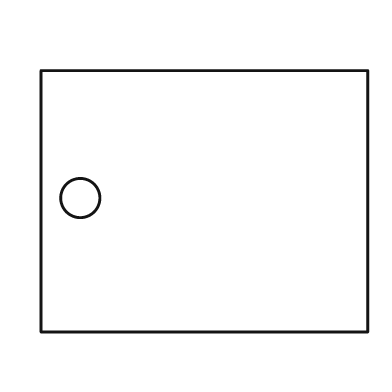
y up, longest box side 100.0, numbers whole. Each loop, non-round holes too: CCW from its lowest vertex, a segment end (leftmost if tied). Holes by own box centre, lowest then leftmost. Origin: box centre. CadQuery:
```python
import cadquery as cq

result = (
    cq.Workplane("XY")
    .moveTo(-50.0, -40.0)
    .lineTo(50.0, -40.0)
    .lineTo(50.0, 40.0)
    .lineTo(-50.0, 40.0)
    .close()
    .moveTo(-38.0, 1.0)
    .circle(6.0)
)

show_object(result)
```